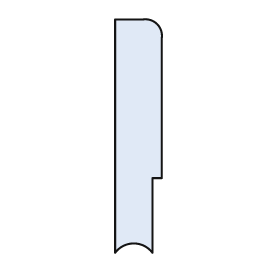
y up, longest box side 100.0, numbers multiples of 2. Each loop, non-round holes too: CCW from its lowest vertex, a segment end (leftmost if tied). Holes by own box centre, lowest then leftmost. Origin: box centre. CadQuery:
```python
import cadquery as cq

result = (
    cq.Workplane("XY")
    .moveTo(-10.0, -50.0)
    .threePointArc((-2.0, -46.0), (6.0, -50.0))
    .lineTo(6.0, -18.0)
    .lineTo(10.0, -18.0)
    .lineTo(10.0, 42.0)
    .threePointArc((8.0, 48.0), (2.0, 50.0))
    .lineTo(-10.0, 50.0)
    .close()
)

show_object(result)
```